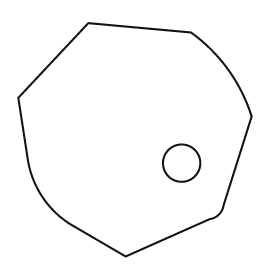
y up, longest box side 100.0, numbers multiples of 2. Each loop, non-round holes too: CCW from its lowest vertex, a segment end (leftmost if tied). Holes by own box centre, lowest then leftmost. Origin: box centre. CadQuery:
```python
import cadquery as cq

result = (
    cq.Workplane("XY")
    .moveTo(-4.0, -50.0)
    .lineTo(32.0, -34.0)
    .threePointArc((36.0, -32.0), (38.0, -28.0))
    .lineTo(50.0, 10.0)
    .threePointArc((40.0, 30.0), (24.0, 46.0))
    .lineTo(-20.0, 50.0)
    .lineTo(-50.0, 18.0)
    .lineTo(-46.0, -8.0)
    .threePointArc((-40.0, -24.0), (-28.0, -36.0))
    .close()
    .moveTo(20.0, -10.0)
    .circle(8.0)
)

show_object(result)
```